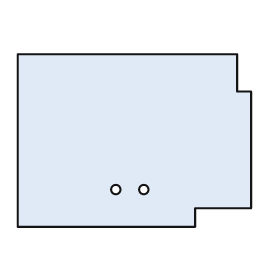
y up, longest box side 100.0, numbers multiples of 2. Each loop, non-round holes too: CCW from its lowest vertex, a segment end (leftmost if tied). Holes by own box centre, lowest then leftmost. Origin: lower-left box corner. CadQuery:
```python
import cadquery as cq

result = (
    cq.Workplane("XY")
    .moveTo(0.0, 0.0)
    .lineTo(76.0, 0.0)
    .lineTo(76.0, 8.0)
    .lineTo(100.0, 8.0)
    .lineTo(100.0, 58.0)
    .lineTo(94.0, 58.0)
    .lineTo(94.0, 74.0)
    .lineTo(0.0, 74.0)
    .close()
    .moveTo(42.0, 16.0)
    .circle(2.0)
    .moveTo(54.0, 16.0)
    .circle(2.0)
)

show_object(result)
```